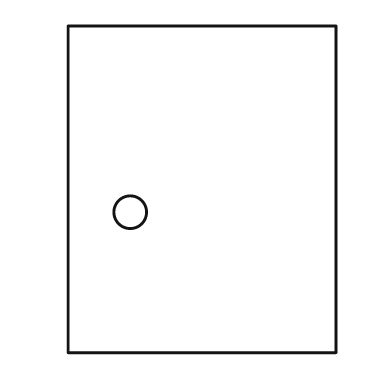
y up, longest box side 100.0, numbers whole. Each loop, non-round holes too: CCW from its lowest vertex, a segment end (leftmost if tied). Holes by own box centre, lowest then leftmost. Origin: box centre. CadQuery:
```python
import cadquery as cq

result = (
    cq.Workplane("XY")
    .moveTo(-41.0, -50.0)
    .lineTo(41.0, -50.0)
    .lineTo(41.0, 50.0)
    .lineTo(-41.0, 50.0)
    .close()
    .moveTo(-22.0, -7.0)
    .circle(5.0)
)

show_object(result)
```